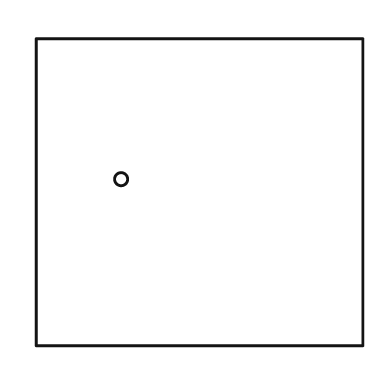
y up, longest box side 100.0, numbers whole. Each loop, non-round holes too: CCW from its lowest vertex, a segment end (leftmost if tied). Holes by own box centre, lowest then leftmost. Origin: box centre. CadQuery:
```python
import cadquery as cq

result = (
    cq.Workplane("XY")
    .moveTo(-50.0, -47.0)
    .lineTo(50.0, -47.0)
    .lineTo(50.0, 47.0)
    .lineTo(-50.0, 47.0)
    .close()
    .moveTo(-24.0, 4.0)
    .circle(2.0)
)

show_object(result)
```